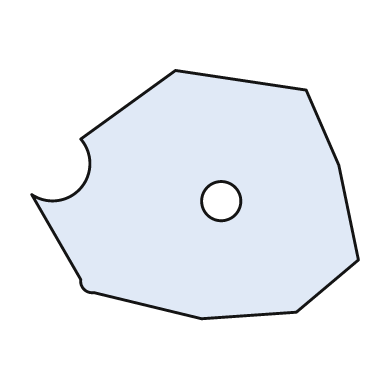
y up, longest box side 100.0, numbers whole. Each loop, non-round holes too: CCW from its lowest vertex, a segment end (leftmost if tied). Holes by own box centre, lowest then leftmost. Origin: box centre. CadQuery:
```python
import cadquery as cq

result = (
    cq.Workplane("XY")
    .moveTo(2.0, -38.0)
    .lineTo(31.0, -36.0)
    .lineTo(50.0, -20.0)
    .lineTo(44.0, 9.0)
    .lineTo(34.0, 32.0)
    .lineTo(-6.0, 38.0)
    .lineTo(-35.0, 17.0)
    .threePointArc((-35.0, 2.0), (-50.0, 0.0))
    .lineTo(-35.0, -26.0)
    .threePointArc((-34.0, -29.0), (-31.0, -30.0))
    .close()
    .moveTo(8.0, -2.0)
    .circle(6.0)
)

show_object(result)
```